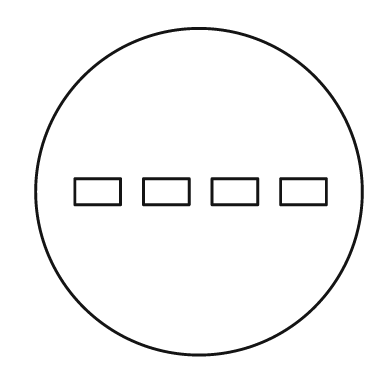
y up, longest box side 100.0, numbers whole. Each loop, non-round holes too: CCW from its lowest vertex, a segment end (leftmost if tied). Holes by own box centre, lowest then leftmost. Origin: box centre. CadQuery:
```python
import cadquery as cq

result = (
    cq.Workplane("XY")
    .moveTo(0.0, 0.0)
    .circle(50.0)
    .moveTo(-38.0, -4.0)
    .lineTo(-24.0, -4.0)
    .lineTo(-24.0, 4.0)
    .lineTo(-38.0, 4.0)
    .close()
    .moveTo(-17.0, -4.0)
    .lineTo(-3.0, -4.0)
    .lineTo(-3.0, 4.0)
    .lineTo(-17.0, 4.0)
    .close()
    .moveTo(4.0, -4.0)
    .lineTo(18.0, -4.0)
    .lineTo(18.0, 4.0)
    .lineTo(4.0, 4.0)
    .close()
    .moveTo(25.0, -4.0)
    .lineTo(39.0, -4.0)
    .lineTo(39.0, 4.0)
    .lineTo(25.0, 4.0)
    .close()
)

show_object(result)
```